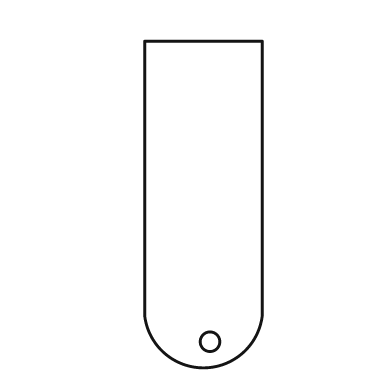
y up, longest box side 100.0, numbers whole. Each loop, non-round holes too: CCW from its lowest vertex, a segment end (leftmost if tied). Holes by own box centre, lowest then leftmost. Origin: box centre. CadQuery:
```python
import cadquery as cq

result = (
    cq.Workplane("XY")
    .moveTo(-18.0, -34.0)
    .threePointArc((0.0, -50.0), (18.0, -34.0))
    .lineTo(18.0, 50.0)
    .lineTo(-18.0, 50.0)
    .close()
    .moveTo(2.0, -42.0)
    .circle(3.0)
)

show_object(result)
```